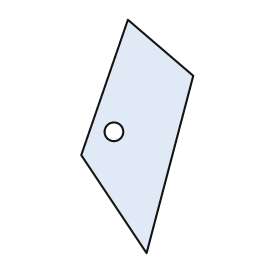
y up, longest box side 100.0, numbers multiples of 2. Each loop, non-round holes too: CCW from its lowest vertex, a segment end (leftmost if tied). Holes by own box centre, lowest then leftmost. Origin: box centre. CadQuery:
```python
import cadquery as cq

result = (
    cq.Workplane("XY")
    .moveTo(4.0, -50.0)
    .lineTo(24.0, 26.0)
    .lineTo(-4.0, 50.0)
    .lineTo(-24.0, -8.0)
    .close()
    .moveTo(-10.0, 2.0)
    .circle(4.0)
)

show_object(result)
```